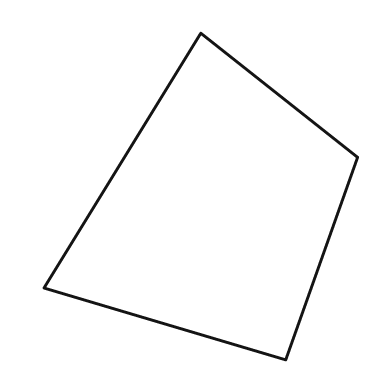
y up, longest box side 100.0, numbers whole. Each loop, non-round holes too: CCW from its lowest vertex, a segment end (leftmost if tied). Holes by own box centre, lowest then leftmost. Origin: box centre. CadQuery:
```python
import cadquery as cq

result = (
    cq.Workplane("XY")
    .moveTo(26.0, -50.0)
    .lineTo(48.0, 12.0)
    .lineTo(0.0, 50.0)
    .lineTo(-48.0, -28.0)
    .close()
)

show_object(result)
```